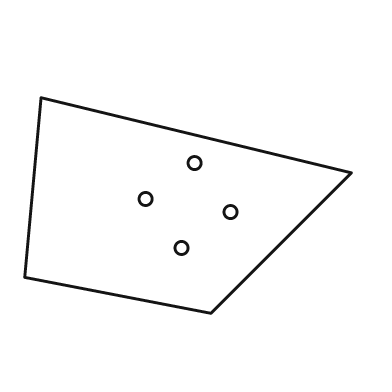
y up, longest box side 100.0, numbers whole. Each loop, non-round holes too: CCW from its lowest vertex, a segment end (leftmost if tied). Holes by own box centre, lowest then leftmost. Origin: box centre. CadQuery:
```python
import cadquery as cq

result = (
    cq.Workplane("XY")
    .moveTo(7.0, -33.0)
    .lineTo(50.0, 10.0)
    .lineTo(-45.0, 33.0)
    .lineTo(-50.0, -22.0)
    .close()
    .moveTo(-2.0, -13.0)
    .circle(2.0)
    .moveTo(13.0, -2.0)
    .circle(2.0)
    .moveTo(-13.0, 2.0)
    .circle(2.0)
    .moveTo(2.0, 13.0)
    .circle(2.0)
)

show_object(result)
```